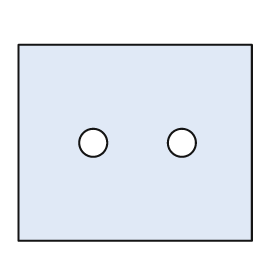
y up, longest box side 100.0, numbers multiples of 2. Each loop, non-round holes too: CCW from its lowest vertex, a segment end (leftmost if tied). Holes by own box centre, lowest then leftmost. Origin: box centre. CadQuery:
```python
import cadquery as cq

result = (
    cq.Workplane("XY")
    .moveTo(-50.0, -42.0)
    .lineTo(50.0, -42.0)
    .lineTo(50.0, 42.0)
    .lineTo(-50.0, 42.0)
    .close()
    .moveTo(-18.0, 0.0)
    .circle(6.0)
    .moveTo(20.0, 0.0)
    .circle(6.0)
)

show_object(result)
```